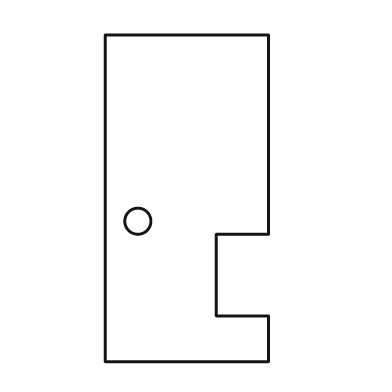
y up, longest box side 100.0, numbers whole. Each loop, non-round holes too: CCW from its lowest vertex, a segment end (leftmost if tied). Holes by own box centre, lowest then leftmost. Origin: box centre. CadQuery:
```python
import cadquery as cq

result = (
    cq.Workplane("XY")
    .moveTo(-25.0, -50.0)
    .lineTo(25.0, -50.0)
    .lineTo(25.0, -36.0)
    .lineTo(9.0, -36.0)
    .lineTo(9.0, -11.0)
    .lineTo(25.0, -11.0)
    .lineTo(25.0, 50.0)
    .lineTo(-25.0, 50.0)
    .close()
    .moveTo(-15.0, -7.0)
    .circle(4.0)
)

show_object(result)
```